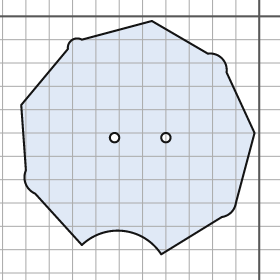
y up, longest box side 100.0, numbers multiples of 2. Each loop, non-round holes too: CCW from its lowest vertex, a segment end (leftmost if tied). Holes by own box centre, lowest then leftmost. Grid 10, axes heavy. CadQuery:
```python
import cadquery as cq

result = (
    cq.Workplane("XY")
    .moveTo(-42.0, -102.0)
    .lineTo(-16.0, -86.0)
    .threePointArc((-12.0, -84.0), (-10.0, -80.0))
    .lineTo(-2.0, -50.0)
    .lineTo(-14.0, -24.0)
    .threePointArc((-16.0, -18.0), (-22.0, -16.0))
    .lineTo(-46.0, -2.0)
    .lineTo(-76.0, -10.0)
    .threePointArc((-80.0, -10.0), (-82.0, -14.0))
    .lineTo(-102.0, -38.0)
    .lineTo(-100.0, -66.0)
    .threePointArc((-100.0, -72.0), (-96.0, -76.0))
    .lineTo(-76.0, -98.0)
    .threePointArc((-58.0, -92.0), (-42.0, -102.0))
    .close()
    .moveTo(-62.0, -52.0)
    .circle(2.0)
    .moveTo(-40.0, -52.0)
    .circle(2.0)
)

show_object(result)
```